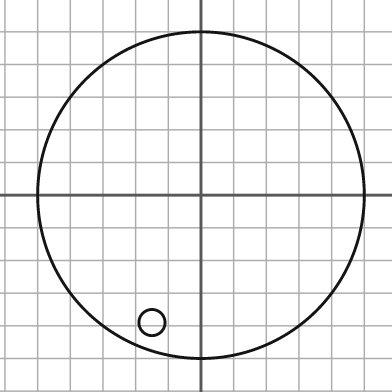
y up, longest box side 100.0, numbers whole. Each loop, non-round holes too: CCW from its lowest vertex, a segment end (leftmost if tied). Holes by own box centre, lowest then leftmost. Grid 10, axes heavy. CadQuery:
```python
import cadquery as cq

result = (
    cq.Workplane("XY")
    .moveTo(0.0, 0.0)
    .circle(50.0)
    .moveTo(-15.0, -39.0)
    .circle(4.0)
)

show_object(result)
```